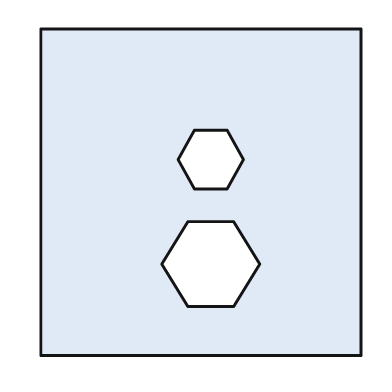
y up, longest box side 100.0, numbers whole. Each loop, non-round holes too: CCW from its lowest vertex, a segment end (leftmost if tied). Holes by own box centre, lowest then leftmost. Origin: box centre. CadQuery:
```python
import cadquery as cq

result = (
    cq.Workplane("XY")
    .moveTo(-49.0, -50.0)
    .lineTo(49.0, -50.0)
    .lineTo(49.0, 50.0)
    .lineTo(-49.0, 50.0)
    .close()
    .moveTo(-4.0, -35.0)
    .lineTo(10.0, -35.0)
    .lineTo(18.0, -22.0)
    .lineTo(10.0, -9.0)
    .lineTo(-4.0, -9.0)
    .lineTo(-12.0, -22.0)
    .close()
    .moveTo(-2.0, 1.0)
    .lineTo(8.0, 1.0)
    .lineTo(13.0, 10.0)
    .lineTo(8.0, 19.0)
    .lineTo(-2.0, 19.0)
    .lineTo(-7.0, 10.0)
    .close()
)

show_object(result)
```